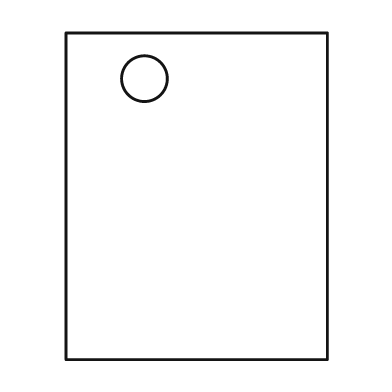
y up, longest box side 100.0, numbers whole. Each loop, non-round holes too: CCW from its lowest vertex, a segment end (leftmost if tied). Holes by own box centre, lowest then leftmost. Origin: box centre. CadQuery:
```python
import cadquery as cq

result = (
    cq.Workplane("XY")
    .moveTo(-40.0, -50.0)
    .lineTo(40.0, -50.0)
    .lineTo(40.0, 50.0)
    .lineTo(-40.0, 50.0)
    .close()
    .moveTo(-16.0, 36.0)
    .circle(7.0)
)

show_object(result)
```